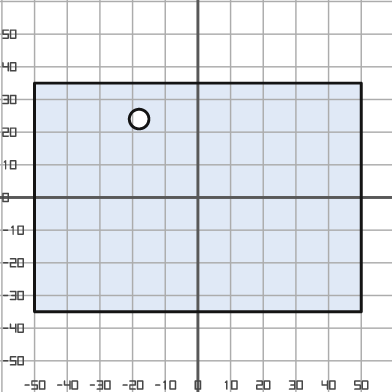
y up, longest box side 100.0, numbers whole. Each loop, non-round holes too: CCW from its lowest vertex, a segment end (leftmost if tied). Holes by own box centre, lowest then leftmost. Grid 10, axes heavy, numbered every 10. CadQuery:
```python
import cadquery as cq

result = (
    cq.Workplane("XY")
    .moveTo(-50.0, -35.0)
    .lineTo(50.0, -35.0)
    .lineTo(50.0, 35.0)
    .lineTo(-50.0, 35.0)
    .close()
    .moveTo(-18.0, 24.0)
    .circle(3.0)
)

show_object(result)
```